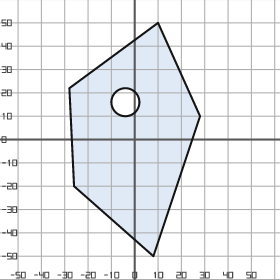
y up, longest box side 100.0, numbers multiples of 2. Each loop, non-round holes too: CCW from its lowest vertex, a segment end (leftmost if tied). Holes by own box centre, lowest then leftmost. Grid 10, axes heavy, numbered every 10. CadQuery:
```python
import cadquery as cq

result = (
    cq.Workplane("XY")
    .moveTo(8.0, -50.0)
    .lineTo(28.0, 10.0)
    .lineTo(10.0, 50.0)
    .lineTo(-28.0, 22.0)
    .lineTo(-26.0, -20.0)
    .close()
    .moveTo(-4.0, 16.0)
    .circle(6.0)
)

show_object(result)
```